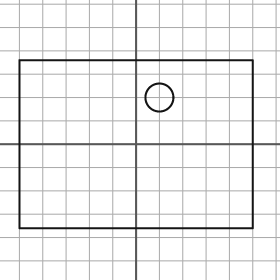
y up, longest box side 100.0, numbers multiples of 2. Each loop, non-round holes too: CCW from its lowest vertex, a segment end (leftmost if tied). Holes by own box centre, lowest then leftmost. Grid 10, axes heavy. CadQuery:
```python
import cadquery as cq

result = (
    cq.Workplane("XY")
    .moveTo(-50.0, -36.0)
    .lineTo(50.0, -36.0)
    .lineTo(50.0, 36.0)
    .lineTo(-50.0, 36.0)
    .close()
    .moveTo(10.0, 20.0)
    .circle(6.0)
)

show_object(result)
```